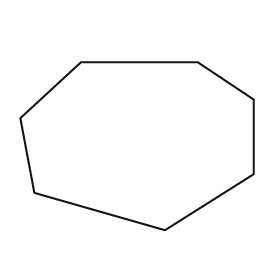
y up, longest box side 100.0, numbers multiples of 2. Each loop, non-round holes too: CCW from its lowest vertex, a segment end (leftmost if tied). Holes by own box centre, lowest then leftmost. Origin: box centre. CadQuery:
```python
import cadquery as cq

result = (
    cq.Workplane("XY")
    .moveTo(12.0, -36.0)
    .lineTo(50.0, -12.0)
    .lineTo(50.0, 20.0)
    .lineTo(26.0, 36.0)
    .lineTo(-24.0, 36.0)
    .lineTo(-50.0, 12.0)
    .lineTo(-44.0, -20.0)
    .close()
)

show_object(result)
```